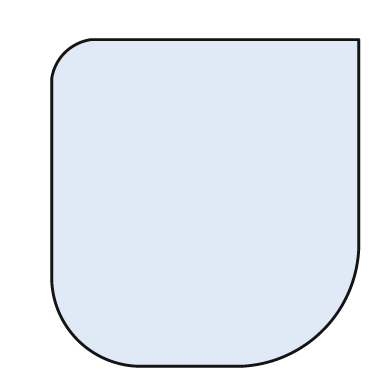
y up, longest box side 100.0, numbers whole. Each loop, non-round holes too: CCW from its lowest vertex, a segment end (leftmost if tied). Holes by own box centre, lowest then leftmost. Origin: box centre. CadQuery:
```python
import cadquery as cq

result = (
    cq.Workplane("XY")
    .moveTo(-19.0, -50.0)
    .lineTo(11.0, -50.0)
    .threePointArc((36.0, -39.0), (47.0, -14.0))
    .lineTo(47.0, 50.0)
    .lineTo(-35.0, 50.0)
    .threePointArc((-43.0, 46.0), (-47.0, 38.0))
    .lineTo(-47.0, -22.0)
    .threePointArc((-39.0, -42.0), (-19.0, -50.0))
    .close()
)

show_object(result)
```